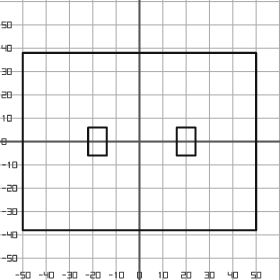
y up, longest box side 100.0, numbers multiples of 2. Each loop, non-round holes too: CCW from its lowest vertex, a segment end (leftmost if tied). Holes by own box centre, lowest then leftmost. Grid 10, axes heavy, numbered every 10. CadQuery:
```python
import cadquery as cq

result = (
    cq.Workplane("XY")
    .moveTo(-50.0, -38.0)
    .lineTo(50.0, -38.0)
    .lineTo(50.0, 38.0)
    .lineTo(-50.0, 38.0)
    .close()
    .moveTo(-22.0, -6.0)
    .lineTo(-14.0, -6.0)
    .lineTo(-14.0, 6.0)
    .lineTo(-22.0, 6.0)
    .close()
    .moveTo(16.0, -6.0)
    .lineTo(24.0, -6.0)
    .lineTo(24.0, 6.0)
    .lineTo(16.0, 6.0)
    .close()
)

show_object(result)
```